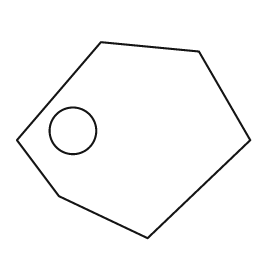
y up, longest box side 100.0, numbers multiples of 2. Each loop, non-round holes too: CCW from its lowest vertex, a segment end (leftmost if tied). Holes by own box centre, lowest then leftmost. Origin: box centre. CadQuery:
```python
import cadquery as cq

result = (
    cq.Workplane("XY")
    .moveTo(6.0, -42.0)
    .lineTo(50.0, 0.0)
    .lineTo(28.0, 38.0)
    .lineTo(-14.0, 42.0)
    .lineTo(-50.0, 0.0)
    .lineTo(-32.0, -24.0)
    .close()
    .moveTo(-26.0, 4.0)
    .circle(10.0)
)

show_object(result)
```